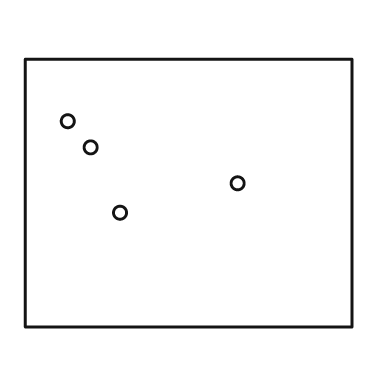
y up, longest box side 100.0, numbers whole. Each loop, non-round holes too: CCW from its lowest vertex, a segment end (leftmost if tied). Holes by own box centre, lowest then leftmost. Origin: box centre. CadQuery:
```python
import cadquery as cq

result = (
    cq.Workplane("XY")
    .moveTo(-50.0, -41.0)
    .lineTo(50.0, -41.0)
    .lineTo(50.0, 41.0)
    .lineTo(-50.0, 41.0)
    .close()
    .moveTo(-21.0, -6.0)
    .circle(2.0)
    .moveTo(15.0, 3.0)
    .circle(2.0)
    .moveTo(-30.0, 14.0)
    .circle(2.0)
    .moveTo(-37.0, 22.0)
    .circle(2.0)
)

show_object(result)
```